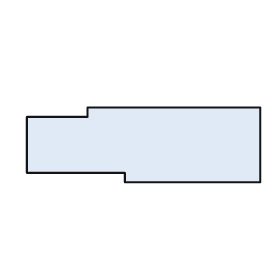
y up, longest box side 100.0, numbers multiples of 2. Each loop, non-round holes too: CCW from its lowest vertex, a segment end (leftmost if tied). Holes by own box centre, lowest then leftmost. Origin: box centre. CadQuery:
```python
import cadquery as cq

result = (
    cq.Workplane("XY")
    .moveTo(-8.0, -16.0)
    .lineTo(50.0, -16.0)
    .lineTo(50.0, 16.0)
    .lineTo(-24.0, 16.0)
    .lineTo(-24.0, 12.0)
    .lineTo(-50.0, 12.0)
    .lineTo(-50.0, -12.0)
    .lineTo(-8.0, -12.0)
    .close()
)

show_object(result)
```